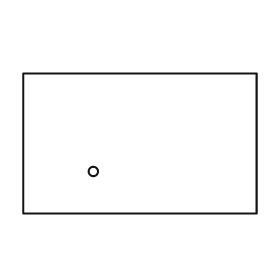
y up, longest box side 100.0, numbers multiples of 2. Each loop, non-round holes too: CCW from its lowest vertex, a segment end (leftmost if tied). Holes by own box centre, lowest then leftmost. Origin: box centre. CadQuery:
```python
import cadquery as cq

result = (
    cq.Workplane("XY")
    .moveTo(-50.0, -30.0)
    .lineTo(50.0, -30.0)
    .lineTo(50.0, 30.0)
    .lineTo(-50.0, 30.0)
    .close()
    .moveTo(-20.0, -12.0)
    .circle(2.0)
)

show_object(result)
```